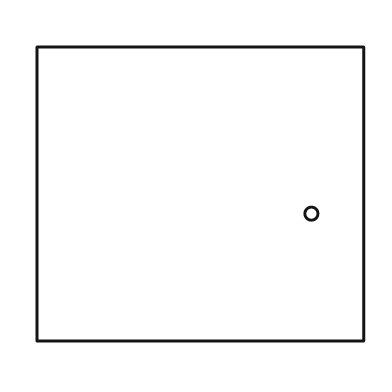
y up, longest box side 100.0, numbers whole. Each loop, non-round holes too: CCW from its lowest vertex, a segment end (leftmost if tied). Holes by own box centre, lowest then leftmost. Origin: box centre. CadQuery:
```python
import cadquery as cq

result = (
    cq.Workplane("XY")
    .moveTo(-50.0, -45.0)
    .lineTo(50.0, -45.0)
    .lineTo(50.0, 45.0)
    .lineTo(-50.0, 45.0)
    .close()
    .moveTo(34.0, -6.0)
    .circle(2.0)
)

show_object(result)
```